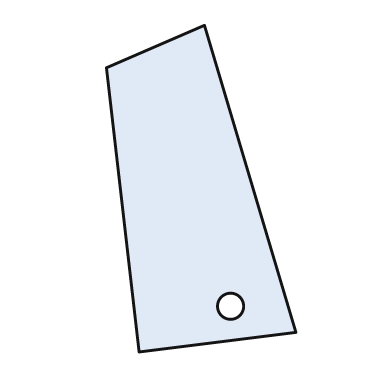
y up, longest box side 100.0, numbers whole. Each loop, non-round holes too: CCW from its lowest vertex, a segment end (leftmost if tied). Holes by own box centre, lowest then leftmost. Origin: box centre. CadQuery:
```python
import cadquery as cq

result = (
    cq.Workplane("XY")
    .moveTo(-19.0, -50.0)
    .lineTo(29.0, -44.0)
    .lineTo(1.0, 50.0)
    .lineTo(-29.0, 37.0)
    .close()
    .moveTo(9.0, -36.0)
    .circle(4.0)
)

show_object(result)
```